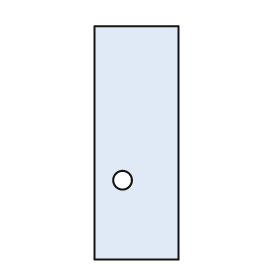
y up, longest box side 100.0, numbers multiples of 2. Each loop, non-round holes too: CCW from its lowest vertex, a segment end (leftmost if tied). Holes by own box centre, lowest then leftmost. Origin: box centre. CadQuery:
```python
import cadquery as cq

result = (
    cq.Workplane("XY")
    .moveTo(-18.0, -50.0)
    .lineTo(18.0, -50.0)
    .lineTo(18.0, 50.0)
    .lineTo(-18.0, 50.0)
    .close()
    .moveTo(-6.0, -16.0)
    .circle(4.0)
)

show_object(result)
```